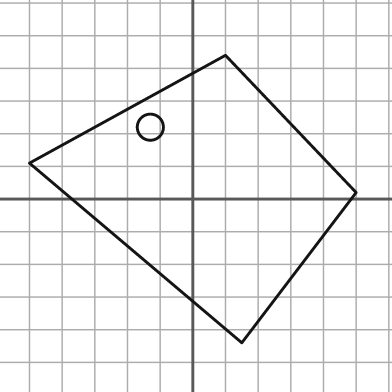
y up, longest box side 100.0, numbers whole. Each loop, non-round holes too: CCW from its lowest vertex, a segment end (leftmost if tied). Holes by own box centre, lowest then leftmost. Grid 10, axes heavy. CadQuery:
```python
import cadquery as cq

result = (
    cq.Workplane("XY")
    .moveTo(15.0, -44.0)
    .lineTo(50.0, 2.0)
    .lineTo(10.0, 44.0)
    .lineTo(-50.0, 11.0)
    .close()
    .moveTo(-13.0, 22.0)
    .circle(4.0)
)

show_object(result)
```